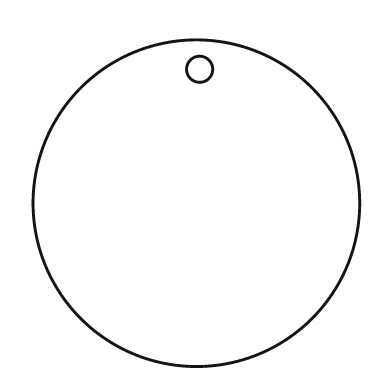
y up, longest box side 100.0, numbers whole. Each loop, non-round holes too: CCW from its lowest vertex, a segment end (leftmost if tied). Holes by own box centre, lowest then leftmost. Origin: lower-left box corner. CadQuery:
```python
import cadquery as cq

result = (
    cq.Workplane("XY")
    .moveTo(50.0, 50.0)
    .circle(50.0)
    .moveTo(51.0, 91.0)
    .circle(4.0)
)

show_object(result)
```